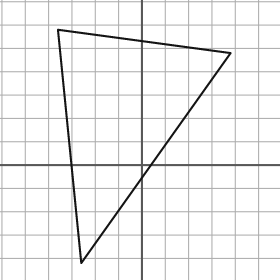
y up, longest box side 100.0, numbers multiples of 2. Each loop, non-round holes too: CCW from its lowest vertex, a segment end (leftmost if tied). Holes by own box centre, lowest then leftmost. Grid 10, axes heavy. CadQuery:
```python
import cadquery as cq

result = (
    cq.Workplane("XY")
    .moveTo(-26.0, -42.0)
    .lineTo(38.0, 48.0)
    .lineTo(-36.0, 58.0)
    .close()
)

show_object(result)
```